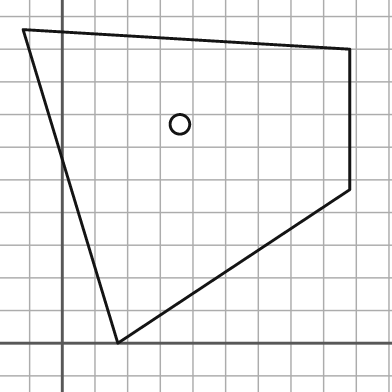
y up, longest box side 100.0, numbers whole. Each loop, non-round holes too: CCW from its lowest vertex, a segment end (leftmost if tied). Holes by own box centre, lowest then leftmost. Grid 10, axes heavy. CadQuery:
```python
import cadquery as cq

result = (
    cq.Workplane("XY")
    .moveTo(17.0, 0.0)
    .lineTo(88.0, 47.0)
    .lineTo(88.0, 90.0)
    .lineTo(-12.0, 96.0)
    .close()
    .moveTo(36.0, 67.0)
    .circle(3.0)
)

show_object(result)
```